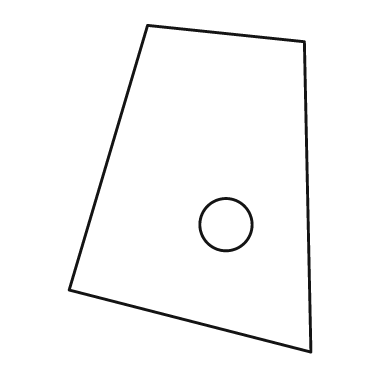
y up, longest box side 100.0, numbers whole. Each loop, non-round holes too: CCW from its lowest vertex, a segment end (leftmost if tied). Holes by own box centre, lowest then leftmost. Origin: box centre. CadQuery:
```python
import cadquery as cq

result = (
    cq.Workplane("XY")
    .moveTo(37.0, -50.0)
    .lineTo(35.0, 45.0)
    .lineTo(-13.0, 50.0)
    .lineTo(-37.0, -31.0)
    .close()
    .moveTo(11.0, -11.0)
    .circle(8.0)
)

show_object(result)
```